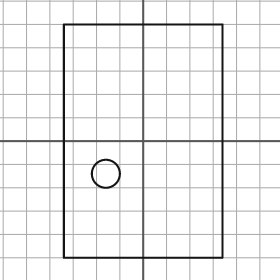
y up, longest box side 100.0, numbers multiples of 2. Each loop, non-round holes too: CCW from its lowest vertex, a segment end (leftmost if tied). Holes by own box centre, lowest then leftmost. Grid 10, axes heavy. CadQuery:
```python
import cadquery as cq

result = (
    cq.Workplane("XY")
    .moveTo(-34.0, -50.0)
    .lineTo(34.0, -50.0)
    .lineTo(34.0, 50.0)
    .lineTo(-34.0, 50.0)
    .close()
    .moveTo(-16.0, -14.0)
    .circle(6.0)
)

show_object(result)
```